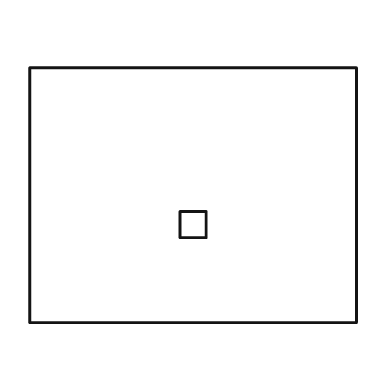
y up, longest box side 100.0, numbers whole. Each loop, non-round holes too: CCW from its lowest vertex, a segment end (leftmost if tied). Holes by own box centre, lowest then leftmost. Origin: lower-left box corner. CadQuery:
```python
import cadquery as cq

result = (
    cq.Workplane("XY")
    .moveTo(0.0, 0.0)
    .lineTo(100.0, 0.0)
    .lineTo(100.0, 78.0)
    .lineTo(0.0, 78.0)
    .close()
    .moveTo(46.0, 26.0)
    .lineTo(54.0, 26.0)
    .lineTo(54.0, 34.0)
    .lineTo(46.0, 34.0)
    .close()
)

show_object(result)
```